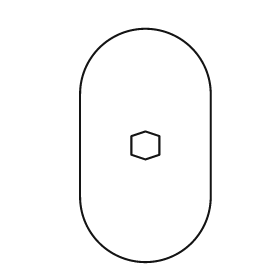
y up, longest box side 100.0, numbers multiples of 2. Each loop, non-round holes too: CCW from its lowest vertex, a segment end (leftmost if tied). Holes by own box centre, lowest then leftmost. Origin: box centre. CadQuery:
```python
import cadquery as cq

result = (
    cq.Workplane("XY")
    .moveTo(-28.0, -22.0)
    .threePointArc((0.0, -50.0), (28.0, -22.0))
    .lineTo(28.0, 22.0)
    .threePointArc((0.0, 50.0), (-28.0, 22.0))
    .close()
    .moveTo(0.0, -6.0)
    .lineTo(6.0, -4.0)
    .lineTo(6.0, 4.0)
    .lineTo(0.0, 6.0)
    .lineTo(-6.0, 4.0)
    .lineTo(-6.0, -4.0)
    .close()
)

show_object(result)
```